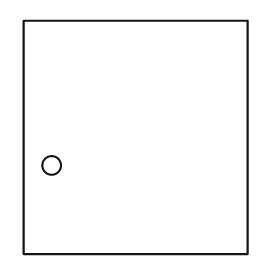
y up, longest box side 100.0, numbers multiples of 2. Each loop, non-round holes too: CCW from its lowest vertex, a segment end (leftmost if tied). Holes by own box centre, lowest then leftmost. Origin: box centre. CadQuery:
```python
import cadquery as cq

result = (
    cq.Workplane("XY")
    .moveTo(-48.0, -50.0)
    .lineTo(48.0, -50.0)
    .lineTo(48.0, 50.0)
    .lineTo(-48.0, 50.0)
    .close()
    .moveTo(-36.0, -12.0)
    .circle(4.0)
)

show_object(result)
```